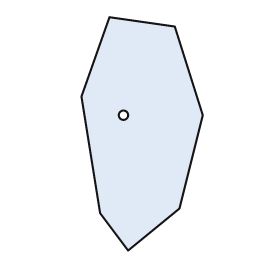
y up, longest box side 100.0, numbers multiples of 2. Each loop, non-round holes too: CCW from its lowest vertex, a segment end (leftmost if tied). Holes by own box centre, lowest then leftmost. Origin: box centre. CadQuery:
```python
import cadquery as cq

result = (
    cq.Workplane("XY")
    .moveTo(-6.0, -50.0)
    .lineTo(16.0, -32.0)
    .lineTo(26.0, 8.0)
    .lineTo(14.0, 46.0)
    .lineTo(-14.0, 50.0)
    .lineTo(-26.0, 16.0)
    .lineTo(-18.0, -34.0)
    .close()
    .moveTo(-8.0, 8.0)
    .circle(2.0)
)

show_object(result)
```